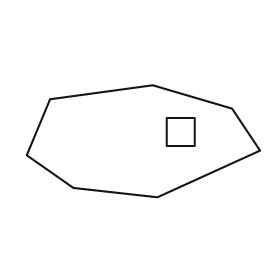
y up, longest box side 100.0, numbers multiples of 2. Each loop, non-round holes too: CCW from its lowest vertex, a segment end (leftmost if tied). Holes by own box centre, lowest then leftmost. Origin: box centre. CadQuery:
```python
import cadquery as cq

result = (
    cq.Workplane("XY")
    .moveTo(6.0, -24.0)
    .lineTo(50.0, -4.0)
    .lineTo(38.0, 14.0)
    .lineTo(4.0, 24.0)
    .lineTo(-40.0, 18.0)
    .lineTo(-50.0, -6.0)
    .lineTo(-30.0, -20.0)
    .close()
    .moveTo(10.0, -2.0)
    .lineTo(22.0, -2.0)
    .lineTo(22.0, 10.0)
    .lineTo(10.0, 10.0)
    .close()
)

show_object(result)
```